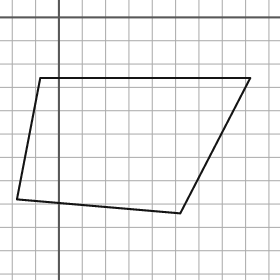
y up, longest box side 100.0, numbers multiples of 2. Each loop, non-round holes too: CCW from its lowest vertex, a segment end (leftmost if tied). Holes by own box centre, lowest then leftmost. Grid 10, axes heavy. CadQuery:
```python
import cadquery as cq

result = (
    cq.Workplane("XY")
    .moveTo(52.0, -84.0)
    .lineTo(82.0, -26.0)
    .lineTo(-8.0, -26.0)
    .lineTo(-18.0, -78.0)
    .close()
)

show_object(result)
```